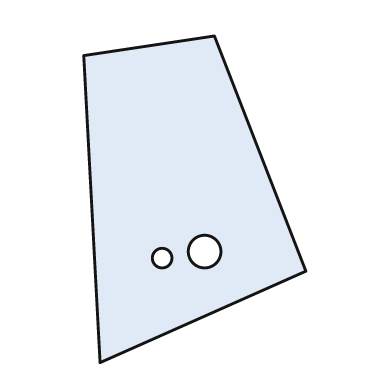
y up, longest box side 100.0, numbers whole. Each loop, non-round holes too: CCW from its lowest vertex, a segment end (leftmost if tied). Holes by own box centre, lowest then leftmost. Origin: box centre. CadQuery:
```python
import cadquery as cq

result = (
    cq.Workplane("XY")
    .moveTo(-29.0, -50.0)
    .lineTo(34.0, -22.0)
    .lineTo(6.0, 50.0)
    .lineTo(-34.0, 44.0)
    .close()
    .moveTo(-10.0, -18.0)
    .circle(3.0)
    .moveTo(3.0, -16.0)
    .circle(5.0)
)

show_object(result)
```